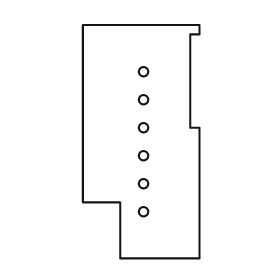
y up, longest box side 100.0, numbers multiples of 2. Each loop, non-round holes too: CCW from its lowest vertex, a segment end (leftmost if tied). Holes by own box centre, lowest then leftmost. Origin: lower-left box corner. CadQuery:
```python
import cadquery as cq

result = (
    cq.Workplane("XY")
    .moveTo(16.0, 0.0)
    .lineTo(50.0, 0.0)
    .lineTo(50.0, 56.0)
    .lineTo(46.0, 56.0)
    .lineTo(46.0, 96.0)
    .lineTo(50.0, 96.0)
    .lineTo(50.0, 100.0)
    .lineTo(0.0, 100.0)
    .lineTo(0.0, 24.0)
    .lineTo(16.0, 24.0)
    .close()
    .moveTo(26.0, 20.0)
    .circle(2.0)
    .moveTo(26.0, 32.0)
    .circle(2.0)
    .moveTo(26.0, 44.0)
    .circle(2.0)
    .moveTo(26.0, 56.0)
    .circle(2.0)
    .moveTo(26.0, 68.0)
    .circle(2.0)
    .moveTo(26.0, 80.0)
    .circle(2.0)
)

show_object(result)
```